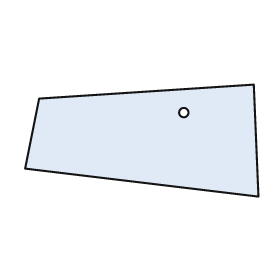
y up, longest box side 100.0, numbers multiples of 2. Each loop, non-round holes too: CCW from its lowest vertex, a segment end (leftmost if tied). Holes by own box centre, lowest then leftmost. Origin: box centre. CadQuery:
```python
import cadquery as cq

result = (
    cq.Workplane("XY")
    .moveTo(50.0, -24.0)
    .lineTo(48.0, 24.0)
    .lineTo(-44.0, 18.0)
    .lineTo(-50.0, -12.0)
    .close()
    .moveTo(18.0, 12.0)
    .circle(2.0)
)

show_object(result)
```